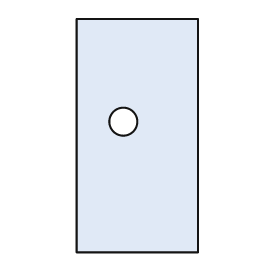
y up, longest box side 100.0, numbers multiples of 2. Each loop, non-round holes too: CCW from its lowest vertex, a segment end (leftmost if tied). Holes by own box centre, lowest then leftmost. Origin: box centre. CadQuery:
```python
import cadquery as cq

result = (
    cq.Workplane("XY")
    .moveTo(-26.0, -50.0)
    .lineTo(26.0, -50.0)
    .lineTo(26.0, 50.0)
    .lineTo(-26.0, 50.0)
    .close()
    .moveTo(-6.0, 6.0)
    .circle(6.0)
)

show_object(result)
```